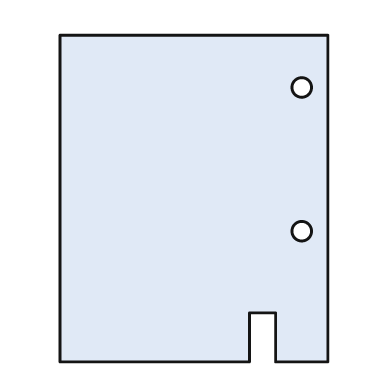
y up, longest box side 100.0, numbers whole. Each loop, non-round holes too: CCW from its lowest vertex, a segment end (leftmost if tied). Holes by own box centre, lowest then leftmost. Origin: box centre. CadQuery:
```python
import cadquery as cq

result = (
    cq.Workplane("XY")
    .moveTo(-41.0, -50.0)
    .lineTo(17.0, -50.0)
    .lineTo(17.0, -35.0)
    .lineTo(25.0, -35.0)
    .lineTo(25.0, -50.0)
    .lineTo(41.0, -50.0)
    .lineTo(41.0, 50.0)
    .lineTo(-41.0, 50.0)
    .close()
    .moveTo(33.0, -10.0)
    .circle(3.0)
    .moveTo(33.0, 34.0)
    .circle(3.0)
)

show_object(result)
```